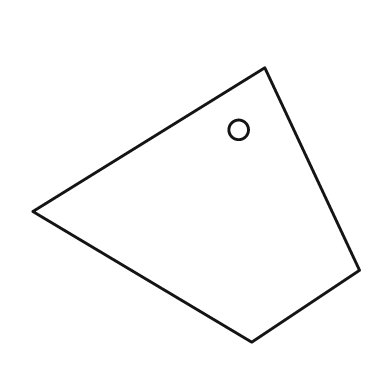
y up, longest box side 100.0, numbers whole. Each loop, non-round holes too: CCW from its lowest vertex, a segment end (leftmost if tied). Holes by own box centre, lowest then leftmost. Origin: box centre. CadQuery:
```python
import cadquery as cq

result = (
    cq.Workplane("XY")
    .moveTo(17.0, -42.0)
    .lineTo(50.0, -20.0)
    .lineTo(21.0, 42.0)
    .lineTo(-50.0, -2.0)
    .close()
    .moveTo(13.0, 23.0)
    .circle(3.0)
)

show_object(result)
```